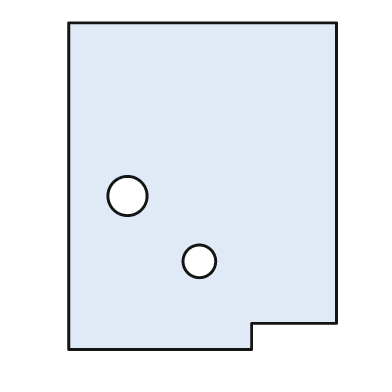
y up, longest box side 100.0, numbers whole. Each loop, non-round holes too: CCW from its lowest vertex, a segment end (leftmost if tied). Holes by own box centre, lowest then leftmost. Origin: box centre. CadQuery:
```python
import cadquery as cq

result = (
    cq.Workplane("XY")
    .moveTo(-41.0, -50.0)
    .lineTo(15.0, -50.0)
    .lineTo(15.0, -42.0)
    .lineTo(41.0, -42.0)
    .lineTo(41.0, 50.0)
    .lineTo(-41.0, 50.0)
    .close()
    .moveTo(-1.0, -23.0)
    .circle(5.0)
    .moveTo(-23.0, -3.0)
    .circle(6.0)
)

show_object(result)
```